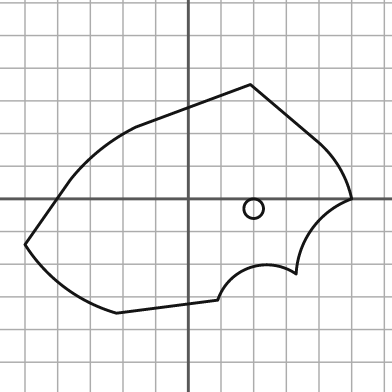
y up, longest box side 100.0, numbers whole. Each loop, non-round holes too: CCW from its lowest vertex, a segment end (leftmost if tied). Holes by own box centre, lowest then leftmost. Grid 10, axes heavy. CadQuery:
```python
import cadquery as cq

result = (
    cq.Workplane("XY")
    .moveTo(-22.0, -35.0)
    .lineTo(9.0, -31.0)
    .threePointArc((19.0, -21.0), (33.0, -23.0))
    .threePointArc((38.0, -9.0), (50.0, 0.0))
    .threePointArc((46.0, 10.0), (39.0, 18.0))
    .lineTo(19.0, 35.0)
    .lineTo(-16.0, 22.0)
    .threePointArc((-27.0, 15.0), (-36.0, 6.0))
    .lineTo(-50.0, -14.0)
    .threePointArc((-38.0, -27.0), (-22.0, -35.0))
    .close()
    .moveTo(20.0, -3.0)
    .circle(3.0)
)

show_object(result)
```